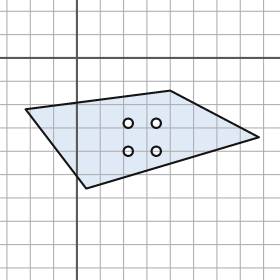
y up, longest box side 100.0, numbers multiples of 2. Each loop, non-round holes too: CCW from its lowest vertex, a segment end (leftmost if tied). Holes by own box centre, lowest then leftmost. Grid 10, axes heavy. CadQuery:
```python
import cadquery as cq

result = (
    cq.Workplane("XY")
    .moveTo(4.0, -56.0)
    .lineTo(78.0, -34.0)
    .lineTo(40.0, -14.0)
    .lineTo(-22.0, -22.0)
    .close()
    .moveTo(22.0, -40.0)
    .circle(2.0)
    .moveTo(34.0, -40.0)
    .circle(2.0)
    .moveTo(22.0, -28.0)
    .circle(2.0)
    .moveTo(34.0, -28.0)
    .circle(2.0)
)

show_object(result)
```